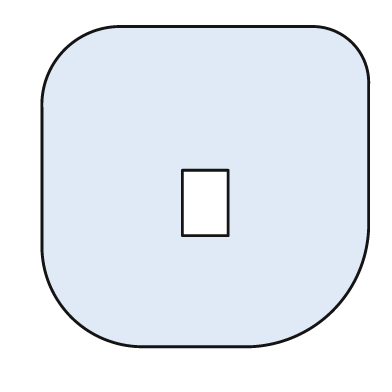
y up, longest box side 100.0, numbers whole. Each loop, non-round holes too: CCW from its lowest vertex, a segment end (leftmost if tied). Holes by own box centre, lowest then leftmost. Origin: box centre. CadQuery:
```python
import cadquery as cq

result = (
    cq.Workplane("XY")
    .moveTo(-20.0, -49.0)
    .lineTo(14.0, -49.0)
    .threePointArc((39.0, -38.0), (50.0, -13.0))
    .lineTo(50.0, 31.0)
    .threePointArc((45.0, 44.0), (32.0, 49.0))
    .lineTo(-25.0, 49.0)
    .threePointArc((-43.0, 42.0), (-50.0, 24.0))
    .lineTo(-50.0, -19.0)
    .threePointArc((-41.0, -40.0), (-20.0, -49.0))
    .close()
    .moveTo(-7.0, -15.0)
    .lineTo(7.0, -15.0)
    .lineTo(7.0, 5.0)
    .lineTo(-7.0, 5.0)
    .close()
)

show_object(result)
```